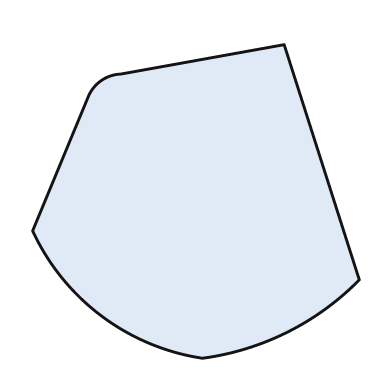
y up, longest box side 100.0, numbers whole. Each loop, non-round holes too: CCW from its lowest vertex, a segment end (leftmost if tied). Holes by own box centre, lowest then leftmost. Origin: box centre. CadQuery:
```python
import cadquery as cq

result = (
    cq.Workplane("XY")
    .moveTo(2.0, -48.0)
    .threePointArc((28.0, -40.0), (50.0, -24.0))
    .lineTo(27.0, 48.0)
    .lineTo(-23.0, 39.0)
    .threePointArc((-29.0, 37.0), (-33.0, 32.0))
    .lineTo(-50.0, -9.0)
    .threePointArc((-29.0, -35.0), (2.0, -48.0))
    .close()
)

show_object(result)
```